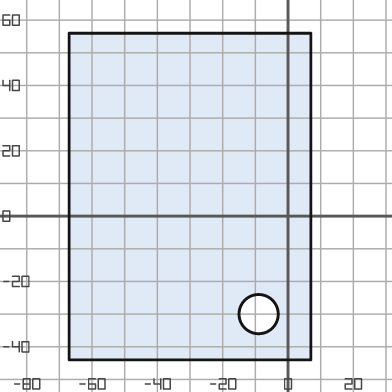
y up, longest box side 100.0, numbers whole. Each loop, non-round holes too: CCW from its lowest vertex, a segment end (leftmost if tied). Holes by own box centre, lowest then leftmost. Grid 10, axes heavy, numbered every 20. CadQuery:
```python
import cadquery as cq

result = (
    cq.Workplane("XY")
    .moveTo(-67.0, -44.0)
    .lineTo(7.0, -44.0)
    .lineTo(7.0, 56.0)
    .lineTo(-67.0, 56.0)
    .close()
    .moveTo(-9.0, -30.0)
    .circle(6.0)
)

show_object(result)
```